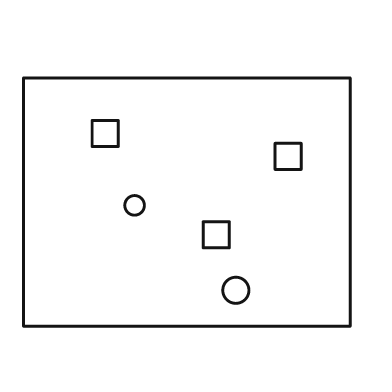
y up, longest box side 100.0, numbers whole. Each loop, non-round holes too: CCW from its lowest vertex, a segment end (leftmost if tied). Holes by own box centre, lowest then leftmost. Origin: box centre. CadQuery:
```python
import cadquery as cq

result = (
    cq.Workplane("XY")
    .moveTo(-50.0, -38.0)
    .lineTo(50.0, -38.0)
    .lineTo(50.0, 38.0)
    .lineTo(-50.0, 38.0)
    .close()
    .moveTo(15.0, -27.0)
    .circle(4.0)
    .moveTo(5.0, -14.0)
    .lineTo(13.0, -14.0)
    .lineTo(13.0, -6.0)
    .lineTo(5.0, -6.0)
    .close()
    .moveTo(-16.0, -1.0)
    .circle(3.0)
    .moveTo(27.0, 10.0)
    .lineTo(35.0, 10.0)
    .lineTo(35.0, 18.0)
    .lineTo(27.0, 18.0)
    .close()
    .moveTo(-29.0, 17.0)
    .lineTo(-21.0, 17.0)
    .lineTo(-21.0, 25.0)
    .lineTo(-29.0, 25.0)
    .close()
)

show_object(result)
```